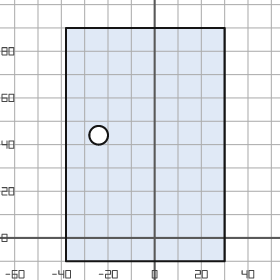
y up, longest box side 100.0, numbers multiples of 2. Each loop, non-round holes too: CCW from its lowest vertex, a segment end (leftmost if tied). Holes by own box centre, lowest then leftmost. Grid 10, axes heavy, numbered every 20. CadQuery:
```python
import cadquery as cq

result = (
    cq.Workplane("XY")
    .moveTo(-38.0, -10.0)
    .lineTo(30.0, -10.0)
    .lineTo(30.0, 90.0)
    .lineTo(-38.0, 90.0)
    .close()
    .moveTo(-24.0, 44.0)
    .circle(4.0)
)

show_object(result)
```